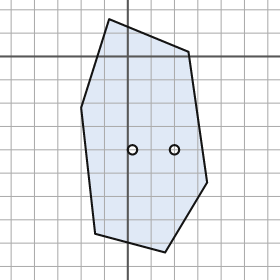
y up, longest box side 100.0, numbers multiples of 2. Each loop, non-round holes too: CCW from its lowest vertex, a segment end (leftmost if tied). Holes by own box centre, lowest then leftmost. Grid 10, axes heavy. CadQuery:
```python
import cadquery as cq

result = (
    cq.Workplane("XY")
    .moveTo(16.0, -84.0)
    .lineTo(34.0, -54.0)
    .lineTo(26.0, 2.0)
    .lineTo(-8.0, 16.0)
    .lineTo(-20.0, -22.0)
    .lineTo(-14.0, -76.0)
    .close()
    .moveTo(2.0, -40.0)
    .circle(2.0)
    .moveTo(20.0, -40.0)
    .circle(2.0)
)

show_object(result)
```